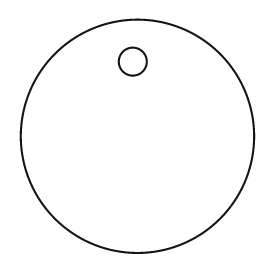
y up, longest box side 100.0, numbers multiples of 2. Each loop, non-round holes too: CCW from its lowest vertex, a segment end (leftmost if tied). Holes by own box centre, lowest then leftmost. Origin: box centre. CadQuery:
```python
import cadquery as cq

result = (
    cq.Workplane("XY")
    .moveTo(0.0, 0.0)
    .circle(50.0)
    .moveTo(-2.0, 32.0)
    .circle(6.0)
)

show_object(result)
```